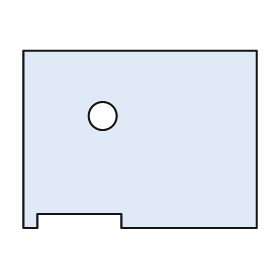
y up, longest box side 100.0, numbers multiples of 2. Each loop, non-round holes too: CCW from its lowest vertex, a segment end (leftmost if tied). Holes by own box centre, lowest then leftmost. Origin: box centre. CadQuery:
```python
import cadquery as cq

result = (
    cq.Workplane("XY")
    .moveTo(-50.0, -38.0)
    .lineTo(-44.0, -38.0)
    .lineTo(-44.0, -32.0)
    .lineTo(-8.0, -32.0)
    .lineTo(-8.0, -38.0)
    .lineTo(50.0, -38.0)
    .lineTo(50.0, 38.0)
    .lineTo(-50.0, 38.0)
    .close()
    .moveTo(-16.0, 10.0)
    .circle(6.0)
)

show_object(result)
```